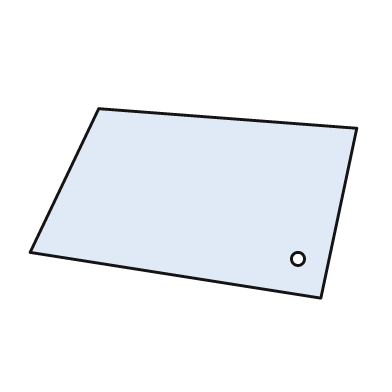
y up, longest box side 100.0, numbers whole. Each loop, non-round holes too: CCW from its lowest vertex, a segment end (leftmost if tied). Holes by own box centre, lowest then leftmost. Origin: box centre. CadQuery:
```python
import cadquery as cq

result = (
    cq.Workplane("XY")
    .moveTo(39.0, -29.0)
    .lineTo(50.0, 23.0)
    .lineTo(-29.0, 29.0)
    .lineTo(-50.0, -15.0)
    .close()
    .moveTo(32.0, -17.0)
    .circle(2.0)
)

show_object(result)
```